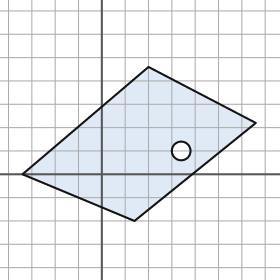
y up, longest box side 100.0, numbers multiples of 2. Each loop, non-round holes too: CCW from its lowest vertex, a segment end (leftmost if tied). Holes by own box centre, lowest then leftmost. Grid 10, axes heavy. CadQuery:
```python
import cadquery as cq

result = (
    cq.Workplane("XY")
    .moveTo(14.0, -20.0)
    .lineTo(66.0, 22.0)
    .lineTo(20.0, 46.0)
    .lineTo(-34.0, 0.0)
    .close()
    .moveTo(34.0, 10.0)
    .circle(4.0)
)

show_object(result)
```